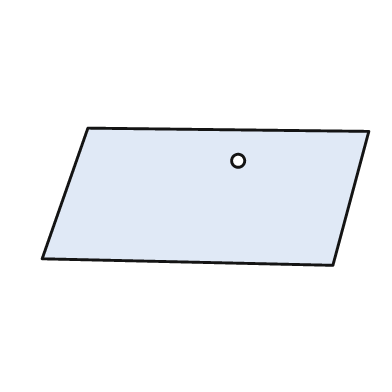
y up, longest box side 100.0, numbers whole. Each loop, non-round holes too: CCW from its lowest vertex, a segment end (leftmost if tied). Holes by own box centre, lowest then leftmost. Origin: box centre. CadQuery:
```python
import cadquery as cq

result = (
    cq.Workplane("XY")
    .moveTo(39.0, -21.0)
    .lineTo(50.0, 20.0)
    .lineTo(-36.0, 21.0)
    .lineTo(-50.0, -19.0)
    .close()
    .moveTo(10.0, 11.0)
    .circle(2.0)
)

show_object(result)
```